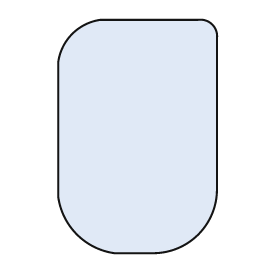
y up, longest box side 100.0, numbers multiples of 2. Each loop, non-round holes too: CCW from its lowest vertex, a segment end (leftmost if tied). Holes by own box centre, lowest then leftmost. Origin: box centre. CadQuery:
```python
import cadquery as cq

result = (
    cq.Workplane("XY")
    .moveTo(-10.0, -50.0)
    .lineTo(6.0, -50.0)
    .threePointArc((26.0, -42.0), (34.0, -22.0))
    .lineTo(34.0, 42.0)
    .threePointArc((32.0, 48.0), (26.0, 50.0))
    .lineTo(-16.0, 50.0)
    .threePointArc((-28.0, 44.0), (-34.0, 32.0))
    .lineTo(-34.0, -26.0)
    .threePointArc((-26.0, -42.0), (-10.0, -50.0))
    .close()
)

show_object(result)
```